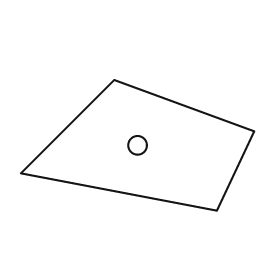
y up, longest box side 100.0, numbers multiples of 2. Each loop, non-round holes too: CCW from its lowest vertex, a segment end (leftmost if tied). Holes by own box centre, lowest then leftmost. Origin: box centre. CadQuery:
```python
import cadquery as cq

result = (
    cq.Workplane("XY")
    .moveTo(34.0, -28.0)
    .lineTo(50.0, 6.0)
    .lineTo(-10.0, 28.0)
    .lineTo(-50.0, -12.0)
    .close()
    .moveTo(0.0, 0.0)
    .circle(4.0)
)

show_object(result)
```